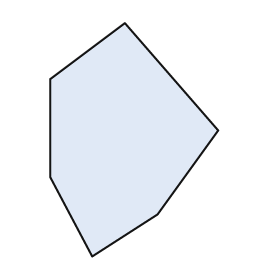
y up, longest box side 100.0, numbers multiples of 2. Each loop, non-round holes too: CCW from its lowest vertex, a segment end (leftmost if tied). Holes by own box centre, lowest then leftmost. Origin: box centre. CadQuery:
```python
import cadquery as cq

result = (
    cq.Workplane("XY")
    .moveTo(-18.0, -50.0)
    .lineTo(10.0, -32.0)
    .lineTo(36.0, 4.0)
    .lineTo(-4.0, 50.0)
    .lineTo(-36.0, 26.0)
    .lineTo(-36.0, -16.0)
    .close()
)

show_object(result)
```